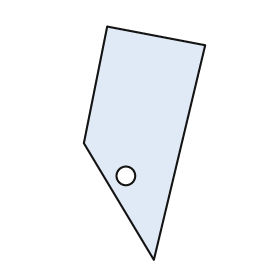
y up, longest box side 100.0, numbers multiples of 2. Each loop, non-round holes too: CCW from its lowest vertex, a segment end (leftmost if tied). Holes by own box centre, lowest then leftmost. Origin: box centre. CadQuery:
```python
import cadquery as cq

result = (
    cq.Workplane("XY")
    .moveTo(4.0, -50.0)
    .lineTo(26.0, 42.0)
    .lineTo(-16.0, 50.0)
    .lineTo(-26.0, 0.0)
    .close()
    .moveTo(-8.0, -14.0)
    .circle(4.0)
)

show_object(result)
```